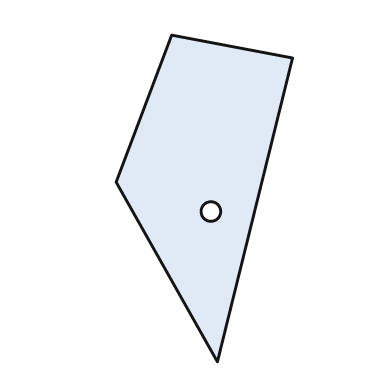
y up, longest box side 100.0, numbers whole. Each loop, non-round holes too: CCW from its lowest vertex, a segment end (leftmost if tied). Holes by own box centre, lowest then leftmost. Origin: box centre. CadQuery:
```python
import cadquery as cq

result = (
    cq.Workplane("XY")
    .moveTo(4.0, -50.0)
    .lineTo(27.0, 43.0)
    .lineTo(-10.0, 50.0)
    .lineTo(-27.0, 5.0)
    .close()
    .moveTo(2.0, -4.0)
    .circle(3.0)
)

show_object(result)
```